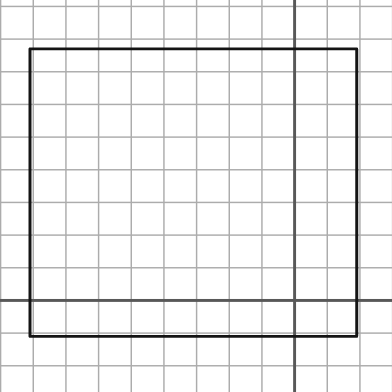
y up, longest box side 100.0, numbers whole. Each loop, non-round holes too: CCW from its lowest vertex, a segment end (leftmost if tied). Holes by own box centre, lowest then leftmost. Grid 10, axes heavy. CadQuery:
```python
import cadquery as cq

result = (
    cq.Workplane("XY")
    .moveTo(-81.0, -11.0)
    .lineTo(19.0, -11.0)
    .lineTo(19.0, 77.0)
    .lineTo(-81.0, 77.0)
    .close()
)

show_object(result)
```